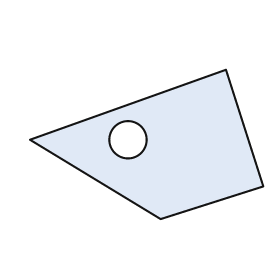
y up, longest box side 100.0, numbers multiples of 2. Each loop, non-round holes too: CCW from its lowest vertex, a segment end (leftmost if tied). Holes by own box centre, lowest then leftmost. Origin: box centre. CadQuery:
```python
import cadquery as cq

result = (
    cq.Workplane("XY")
    .moveTo(6.0, -32.0)
    .lineTo(50.0, -18.0)
    .lineTo(34.0, 32.0)
    .lineTo(-50.0, 2.0)
    .close()
    .moveTo(-8.0, 2.0)
    .circle(8.0)
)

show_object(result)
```